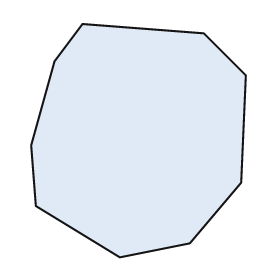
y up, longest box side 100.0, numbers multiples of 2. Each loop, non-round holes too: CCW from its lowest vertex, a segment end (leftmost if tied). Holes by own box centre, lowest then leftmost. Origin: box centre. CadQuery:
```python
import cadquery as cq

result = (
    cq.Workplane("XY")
    .moveTo(-8.0, -50.0)
    .lineTo(22.0, -44.0)
    .lineTo(44.0, -18.0)
    .lineTo(46.0, 28.0)
    .lineTo(28.0, 46.0)
    .lineTo(-24.0, 50.0)
    .lineTo(-36.0, 34.0)
    .lineTo(-46.0, -2.0)
    .lineTo(-44.0, -28.0)
    .close()
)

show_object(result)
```